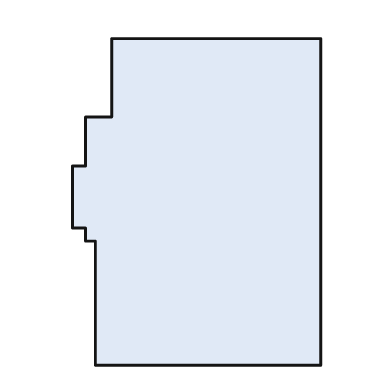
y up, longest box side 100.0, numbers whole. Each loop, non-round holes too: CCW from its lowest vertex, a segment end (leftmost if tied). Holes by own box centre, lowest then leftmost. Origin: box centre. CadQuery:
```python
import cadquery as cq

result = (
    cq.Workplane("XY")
    .moveTo(-31.0, -50.0)
    .lineTo(38.0, -50.0)
    .lineTo(38.0, 50.0)
    .lineTo(-26.0, 50.0)
    .lineTo(-26.0, 26.0)
    .lineTo(-34.0, 26.0)
    .lineTo(-34.0, 11.0)
    .lineTo(-38.0, 11.0)
    .lineTo(-38.0, -8.0)
    .lineTo(-34.0, -8.0)
    .lineTo(-34.0, -12.0)
    .lineTo(-31.0, -12.0)
    .close()
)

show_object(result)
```